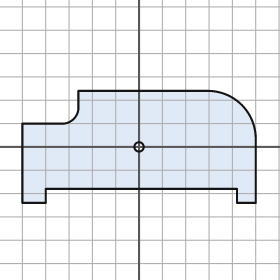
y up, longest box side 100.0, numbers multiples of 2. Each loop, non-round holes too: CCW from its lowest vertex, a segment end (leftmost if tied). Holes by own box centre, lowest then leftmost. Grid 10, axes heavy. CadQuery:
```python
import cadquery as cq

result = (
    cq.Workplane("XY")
    .moveTo(-50.0, -24.0)
    .lineTo(-40.0, -24.0)
    .lineTo(-40.0, -18.0)
    .lineTo(42.0, -18.0)
    .lineTo(42.0, -24.0)
    .lineTo(50.0, -24.0)
    .lineTo(50.0, 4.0)
    .threePointArc((44.0, 18.0), (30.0, 24.0))
    .lineTo(-26.0, 24.0)
    .lineTo(-26.0, 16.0)
    .threePointArc((-28.0, 12.0), (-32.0, 10.0))
    .lineTo(-50.0, 10.0)
    .close()
    .moveTo(0.0, 0.0)
    .circle(2.0)
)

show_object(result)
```